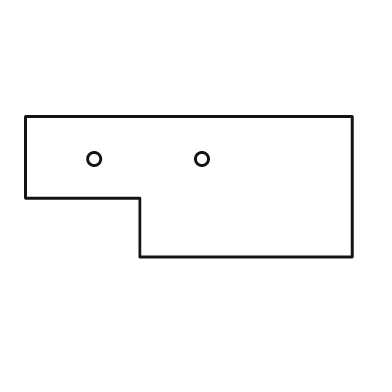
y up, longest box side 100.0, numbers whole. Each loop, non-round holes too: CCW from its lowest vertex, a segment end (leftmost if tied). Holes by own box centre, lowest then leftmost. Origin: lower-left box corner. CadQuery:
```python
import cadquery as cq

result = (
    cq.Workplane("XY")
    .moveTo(35.0, 0.0)
    .lineTo(100.0, 0.0)
    .lineTo(100.0, 43.0)
    .lineTo(0.0, 43.0)
    .lineTo(0.0, 18.0)
    .lineTo(35.0, 18.0)
    .close()
    .moveTo(21.0, 30.0)
    .circle(2.0)
    .moveTo(54.0, 30.0)
    .circle(2.0)
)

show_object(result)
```